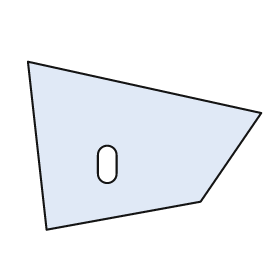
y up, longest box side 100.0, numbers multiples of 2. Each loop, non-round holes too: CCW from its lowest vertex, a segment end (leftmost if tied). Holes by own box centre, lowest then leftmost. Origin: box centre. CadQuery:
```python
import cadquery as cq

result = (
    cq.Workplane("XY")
    .moveTo(-42.0, -36.0)
    .lineTo(24.0, -24.0)
    .lineTo(50.0, 14.0)
    .lineTo(-50.0, 36.0)
    .close()
    .moveTo(-20.0, -12.0)
    .threePointArc((-16.0, -16.0), (-12.0, -12.0))
    .lineTo(-12.0, -4.0)
    .threePointArc((-16.0, 0.0), (-20.0, -4.0))
    .close()
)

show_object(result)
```